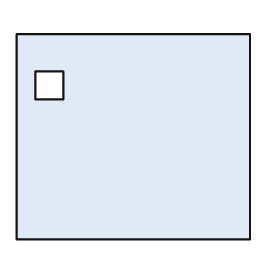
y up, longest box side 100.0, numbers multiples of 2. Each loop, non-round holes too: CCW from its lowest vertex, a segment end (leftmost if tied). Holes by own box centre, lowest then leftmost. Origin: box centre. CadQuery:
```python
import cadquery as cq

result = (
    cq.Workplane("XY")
    .moveTo(-50.0, -44.0)
    .lineTo(50.0, -44.0)
    .lineTo(50.0, 44.0)
    .lineTo(-50.0, 44.0)
    .close()
    .moveTo(-42.0, 16.0)
    .lineTo(-30.0, 16.0)
    .lineTo(-30.0, 28.0)
    .lineTo(-42.0, 28.0)
    .close()
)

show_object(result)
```